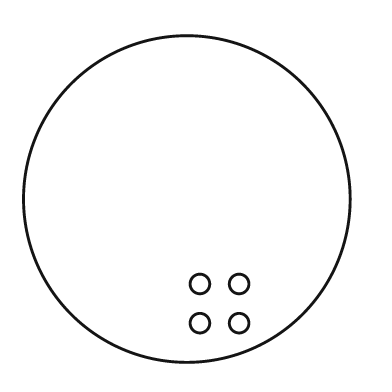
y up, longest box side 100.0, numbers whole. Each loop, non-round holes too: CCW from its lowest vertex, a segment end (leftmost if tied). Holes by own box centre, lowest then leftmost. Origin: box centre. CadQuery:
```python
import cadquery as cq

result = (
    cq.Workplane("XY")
    .moveTo(0.0, 0.0)
    .circle(50.0)
    .moveTo(4.0, -38.0)
    .circle(3.0)
    .moveTo(16.0, -38.0)
    .circle(3.0)
    .moveTo(4.0, -26.0)
    .circle(3.0)
    .moveTo(16.0, -26.0)
    .circle(3.0)
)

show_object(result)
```